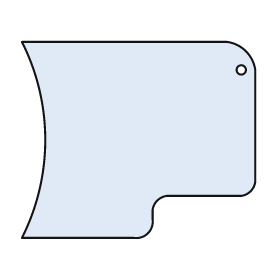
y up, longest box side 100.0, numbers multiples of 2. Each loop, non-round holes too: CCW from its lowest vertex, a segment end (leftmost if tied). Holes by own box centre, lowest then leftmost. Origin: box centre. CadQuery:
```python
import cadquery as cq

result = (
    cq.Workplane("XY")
    .moveTo(-50.0, -42.0)
    .lineTo(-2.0, -42.0)
    .threePointArc((4.0, -40.0), (6.0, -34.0))
    .lineTo(6.0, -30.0)
    .threePointArc((8.0, -26.0), (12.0, -24.0))
    .lineTo(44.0, -24.0)
    .threePointArc((48.0, -22.0), (50.0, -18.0))
    .lineTo(50.0, 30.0)
    .threePointArc((46.0, 38.0), (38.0, 42.0))
    .lineTo(-50.0, 42.0)
    .threePointArc((-40.0, 0.0), (-50.0, -42.0))
    .close()
    .moveTo(44.0, 30.0)
    .circle(2.0)
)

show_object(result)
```